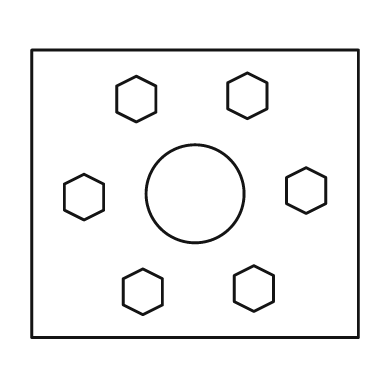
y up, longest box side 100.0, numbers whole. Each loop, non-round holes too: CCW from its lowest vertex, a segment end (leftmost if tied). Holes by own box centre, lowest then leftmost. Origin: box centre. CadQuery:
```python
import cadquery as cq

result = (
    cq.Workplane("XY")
    .moveTo(-50.0, -44.0)
    .lineTo(50.0, -44.0)
    .lineTo(50.0, 44.0)
    .lineTo(-50.0, 44.0)
    .close()
    .moveTo(-16.0, -37.0)
    .lineTo(-10.0, -34.0)
    .lineTo(-10.0, -26.0)
    .lineTo(-16.0, -23.0)
    .lineTo(-22.0, -26.0)
    .lineTo(-22.0, -34.0)
    .close()
    .moveTo(18.0, -36.0)
    .lineTo(24.0, -33.0)
    .lineTo(24.0, -25.0)
    .lineTo(18.0, -22.0)
    .lineTo(12.0, -25.0)
    .lineTo(12.0, -33.0)
    .close()
    .moveTo(-34.0, -8.0)
    .lineTo(-28.0, -5.0)
    .lineTo(-28.0, 3.0)
    .lineTo(-34.0, 6.0)
    .lineTo(-40.0, 3.0)
    .lineTo(-40.0, -5.0)
    .close()
    .moveTo(0.0, 0.0)
    .circle(15.0)
    .moveTo(34.0, -6.0)
    .lineTo(40.0, -3.0)
    .lineTo(40.0, 5.0)
    .lineTo(34.0, 8.0)
    .lineTo(28.0, 5.0)
    .lineTo(28.0, -3.0)
    .close()
    .moveTo(-18.0, 22.0)
    .lineTo(-12.0, 25.0)
    .lineTo(-12.0, 33.0)
    .lineTo(-18.0, 36.0)
    .lineTo(-24.0, 33.0)
    .lineTo(-24.0, 25.0)
    .close()
    .moveTo(16.0, 23.0)
    .lineTo(22.0, 26.0)
    .lineTo(22.0, 34.0)
    .lineTo(16.0, 37.0)
    .lineTo(10.0, 34.0)
    .lineTo(10.0, 26.0)
    .close()
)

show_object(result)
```